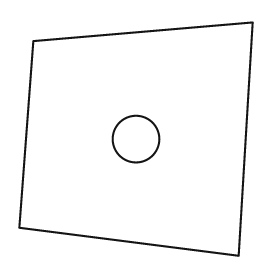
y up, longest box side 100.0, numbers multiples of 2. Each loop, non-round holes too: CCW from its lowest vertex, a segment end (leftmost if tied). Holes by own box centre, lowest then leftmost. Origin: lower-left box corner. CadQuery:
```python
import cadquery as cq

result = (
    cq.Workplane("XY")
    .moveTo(94.0, 0.0)
    .lineTo(100.0, 100.0)
    .lineTo(6.0, 92.0)
    .lineTo(0.0, 12.0)
    .close()
    .moveTo(50.0, 50.0)
    .circle(10.0)
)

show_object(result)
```